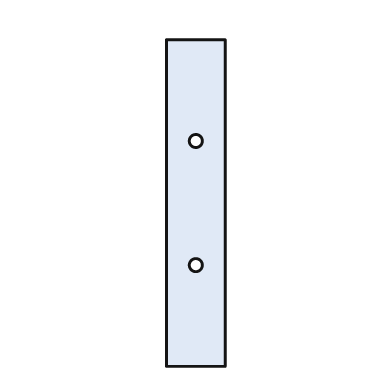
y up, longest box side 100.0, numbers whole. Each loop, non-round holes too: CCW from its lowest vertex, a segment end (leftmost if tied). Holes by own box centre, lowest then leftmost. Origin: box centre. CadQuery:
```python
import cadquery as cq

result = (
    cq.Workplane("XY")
    .moveTo(-9.0, -50.0)
    .lineTo(9.0, -50.0)
    .lineTo(9.0, 50.0)
    .lineTo(-9.0, 50.0)
    .close()
    .moveTo(0.0, -19.0)
    .circle(2.0)
    .moveTo(0.0, 19.0)
    .circle(2.0)
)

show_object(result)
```